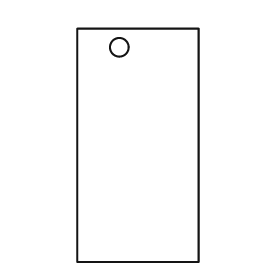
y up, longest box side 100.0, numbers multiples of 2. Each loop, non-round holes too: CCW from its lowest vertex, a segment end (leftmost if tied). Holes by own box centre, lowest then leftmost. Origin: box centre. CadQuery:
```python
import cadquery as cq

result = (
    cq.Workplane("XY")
    .moveTo(-26.0, -50.0)
    .lineTo(26.0, -50.0)
    .lineTo(26.0, 50.0)
    .lineTo(-26.0, 50.0)
    .close()
    .moveTo(-8.0, 42.0)
    .circle(4.0)
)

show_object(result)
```